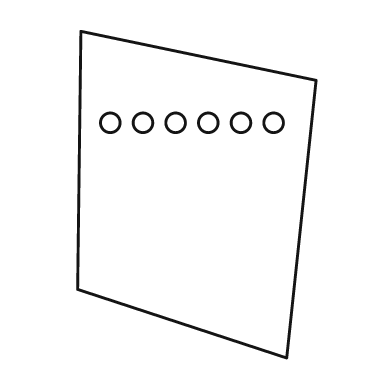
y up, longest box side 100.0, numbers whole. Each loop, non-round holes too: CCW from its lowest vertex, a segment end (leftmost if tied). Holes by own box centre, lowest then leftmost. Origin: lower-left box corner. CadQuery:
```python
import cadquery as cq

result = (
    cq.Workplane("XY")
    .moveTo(64.0, 0.0)
    .lineTo(73.0, 85.0)
    .lineTo(1.0, 100.0)
    .lineTo(0.0, 21.0)
    .close()
    .moveTo(10.0, 72.0)
    .circle(3.0)
    .moveTo(20.0, 72.0)
    .circle(3.0)
    .moveTo(30.0, 72.0)
    .circle(3.0)
    .moveTo(40.0, 72.0)
    .circle(3.0)
    .moveTo(50.0, 72.0)
    .circle(3.0)
    .moveTo(60.0, 72.0)
    .circle(3.0)
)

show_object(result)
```